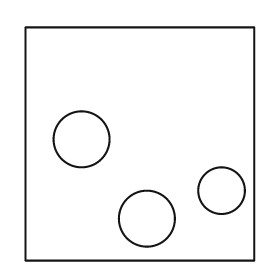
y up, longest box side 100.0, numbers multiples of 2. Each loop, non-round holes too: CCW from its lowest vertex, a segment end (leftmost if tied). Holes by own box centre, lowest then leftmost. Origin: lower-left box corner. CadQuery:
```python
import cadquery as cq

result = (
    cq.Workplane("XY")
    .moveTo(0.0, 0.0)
    .lineTo(98.0, 0.0)
    .lineTo(98.0, 100.0)
    .lineTo(0.0, 100.0)
    .close()
    .moveTo(52.0, 18.0)
    .circle(12.0)
    .moveTo(84.0, 30.0)
    .circle(10.0)
    .moveTo(24.0, 52.0)
    .circle(12.0)
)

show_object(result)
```